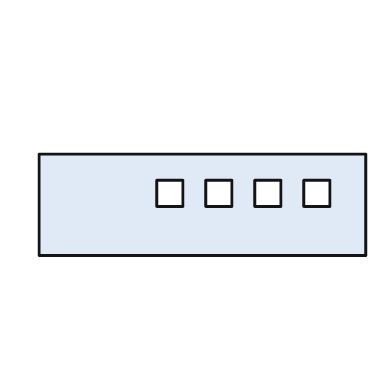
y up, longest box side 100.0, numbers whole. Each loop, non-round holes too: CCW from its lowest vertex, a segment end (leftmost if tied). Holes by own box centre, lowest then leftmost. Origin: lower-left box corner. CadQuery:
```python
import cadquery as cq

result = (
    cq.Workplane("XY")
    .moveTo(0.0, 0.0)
    .lineTo(100.0, 0.0)
    .lineTo(100.0, 31.0)
    .lineTo(0.0, 31.0)
    .close()
    .moveTo(36.0, 15.0)
    .lineTo(44.0, 15.0)
    .lineTo(44.0, 23.0)
    .lineTo(36.0, 23.0)
    .close()
    .moveTo(51.0, 15.0)
    .lineTo(59.0, 15.0)
    .lineTo(59.0, 23.0)
    .lineTo(51.0, 23.0)
    .close()
    .moveTo(66.0, 15.0)
    .lineTo(74.0, 15.0)
    .lineTo(74.0, 23.0)
    .lineTo(66.0, 23.0)
    .close()
    .moveTo(81.0, 15.0)
    .lineTo(89.0, 15.0)
    .lineTo(89.0, 23.0)
    .lineTo(81.0, 23.0)
    .close()
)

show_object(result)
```